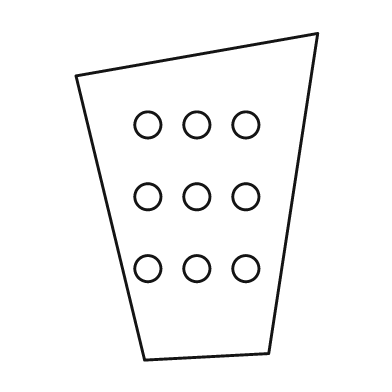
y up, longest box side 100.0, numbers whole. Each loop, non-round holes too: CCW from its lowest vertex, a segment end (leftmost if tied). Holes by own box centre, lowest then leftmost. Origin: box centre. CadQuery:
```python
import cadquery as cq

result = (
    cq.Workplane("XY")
    .moveTo(-16.0, -50.0)
    .lineTo(22.0, -48.0)
    .lineTo(37.0, 50.0)
    .lineTo(-37.0, 37.0)
    .close()
    .moveTo(-15.0, -22.0)
    .circle(4.0)
    .moveTo(0.0, -22.0)
    .circle(4.0)
    .moveTo(15.0, -22.0)
    .circle(4.0)
    .moveTo(-15.0, 0.0)
    .circle(4.0)
    .moveTo(0.0, 0.0)
    .circle(4.0)
    .moveTo(15.0, 0.0)
    .circle(4.0)
    .moveTo(-15.0, 22.0)
    .circle(4.0)
    .moveTo(0.0, 22.0)
    .circle(4.0)
    .moveTo(15.0, 22.0)
    .circle(4.0)
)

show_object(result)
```